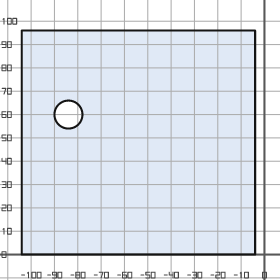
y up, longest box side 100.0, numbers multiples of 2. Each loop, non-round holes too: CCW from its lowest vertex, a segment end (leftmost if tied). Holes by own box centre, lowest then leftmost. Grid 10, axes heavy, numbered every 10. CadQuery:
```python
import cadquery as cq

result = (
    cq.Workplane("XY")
    .moveTo(-104.0, 0.0)
    .lineTo(-4.0, 0.0)
    .lineTo(-4.0, 96.0)
    .lineTo(-104.0, 96.0)
    .close()
    .moveTo(-84.0, 60.0)
    .circle(6.0)
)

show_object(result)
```